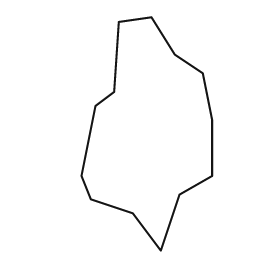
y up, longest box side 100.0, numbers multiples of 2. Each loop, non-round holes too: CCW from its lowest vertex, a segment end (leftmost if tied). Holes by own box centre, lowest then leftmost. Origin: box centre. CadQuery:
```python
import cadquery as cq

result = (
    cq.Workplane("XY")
    .moveTo(6.0, -50.0)
    .lineTo(14.0, -26.0)
    .lineTo(28.0, -18.0)
    .lineTo(28.0, 6.0)
    .lineTo(24.0, 26.0)
    .lineTo(12.0, 34.0)
    .lineTo(2.0, 50.0)
    .lineTo(-12.0, 48.0)
    .lineTo(-14.0, 18.0)
    .lineTo(-22.0, 12.0)
    .lineTo(-28.0, -18.0)
    .lineTo(-24.0, -28.0)
    .lineTo(-6.0, -34.0)
    .close()
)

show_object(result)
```